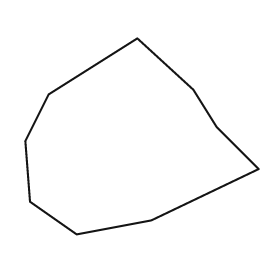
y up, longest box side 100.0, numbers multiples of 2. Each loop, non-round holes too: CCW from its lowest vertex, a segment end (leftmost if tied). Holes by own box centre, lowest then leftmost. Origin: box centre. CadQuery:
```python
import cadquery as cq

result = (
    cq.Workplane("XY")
    .moveTo(-28.0, -42.0)
    .lineTo(4.0, -36.0)
    .lineTo(50.0, -14.0)
    .lineTo(32.0, 4.0)
    .lineTo(22.0, 20.0)
    .lineTo(-2.0, 42.0)
    .lineTo(-40.0, 18.0)
    .lineTo(-50.0, -2.0)
    .lineTo(-48.0, -28.0)
    .close()
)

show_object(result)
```